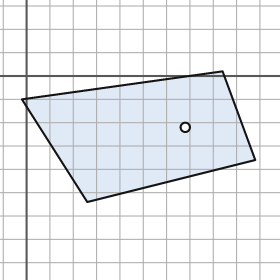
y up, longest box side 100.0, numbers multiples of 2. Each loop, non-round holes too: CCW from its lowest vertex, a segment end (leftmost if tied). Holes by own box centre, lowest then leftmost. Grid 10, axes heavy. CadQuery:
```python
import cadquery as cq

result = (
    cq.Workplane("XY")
    .moveTo(26.0, -54.0)
    .lineTo(98.0, -36.0)
    .lineTo(84.0, 2.0)
    .lineTo(-2.0, -10.0)
    .close()
    .moveTo(68.0, -22.0)
    .circle(2.0)
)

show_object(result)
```